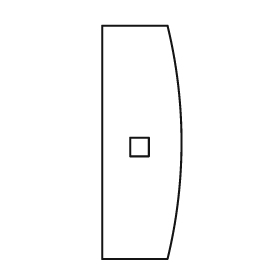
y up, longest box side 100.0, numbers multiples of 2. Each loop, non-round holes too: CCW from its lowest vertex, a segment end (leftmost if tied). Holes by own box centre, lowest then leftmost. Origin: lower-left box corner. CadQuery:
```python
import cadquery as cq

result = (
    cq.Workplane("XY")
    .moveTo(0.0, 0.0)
    .lineTo(28.0, 0.0)
    .threePointArc((34.0, 50.0), (28.0, 100.0))
    .lineTo(0.0, 100.0)
    .close()
    .moveTo(12.0, 44.0)
    .lineTo(20.0, 44.0)
    .lineTo(20.0, 52.0)
    .lineTo(12.0, 52.0)
    .close()
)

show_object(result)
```